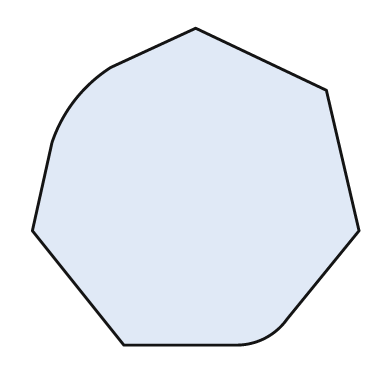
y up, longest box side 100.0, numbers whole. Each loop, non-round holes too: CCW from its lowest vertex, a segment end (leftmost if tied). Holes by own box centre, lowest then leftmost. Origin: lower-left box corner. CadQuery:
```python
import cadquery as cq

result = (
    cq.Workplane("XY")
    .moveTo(28.0, 0.0)
    .lineTo(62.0, 0.0)
    .threePointArc((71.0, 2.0), (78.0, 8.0))
    .lineTo(100.0, 35.0)
    .lineTo(90.0, 78.0)
    .lineTo(50.0, 97.0)
    .lineTo(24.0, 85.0)
    .threePointArc((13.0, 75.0), (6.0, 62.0))
    .lineTo(0.0, 35.0)
    .close()
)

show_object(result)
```